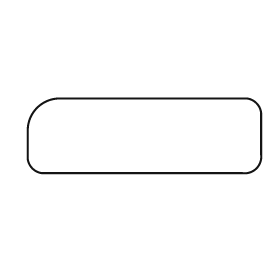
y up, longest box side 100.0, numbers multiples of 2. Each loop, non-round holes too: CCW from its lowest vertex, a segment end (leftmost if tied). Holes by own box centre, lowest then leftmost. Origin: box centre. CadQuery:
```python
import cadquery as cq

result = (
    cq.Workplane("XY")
    .moveTo(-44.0, -16.0)
    .lineTo(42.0, -16.0)
    .threePointArc((48.0, -14.0), (50.0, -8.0))
    .lineTo(50.0, 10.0)
    .threePointArc((48.0, 14.0), (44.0, 16.0))
    .lineTo(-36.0, 16.0)
    .threePointArc((-46.0, 12.0), (-50.0, 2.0))
    .lineTo(-50.0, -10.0)
    .threePointArc((-48.0, -14.0), (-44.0, -16.0))
    .close()
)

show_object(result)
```